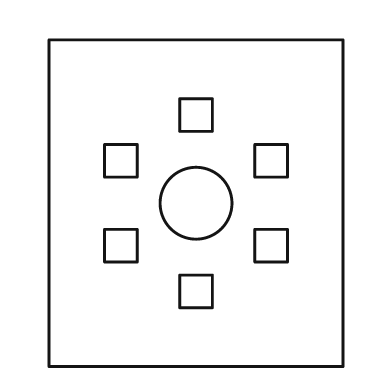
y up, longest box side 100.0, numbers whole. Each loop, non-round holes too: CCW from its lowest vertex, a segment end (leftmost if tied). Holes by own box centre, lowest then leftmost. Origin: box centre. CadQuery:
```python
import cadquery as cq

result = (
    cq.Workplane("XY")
    .moveTo(-45.0, -50.0)
    .lineTo(45.0, -50.0)
    .lineTo(45.0, 50.0)
    .lineTo(-45.0, 50.0)
    .close()
    .moveTo(-5.0, -32.0)
    .lineTo(5.0, -32.0)
    .lineTo(5.0, -22.0)
    .lineTo(-5.0, -22.0)
    .close()
    .moveTo(-28.0, -18.0)
    .lineTo(-18.0, -18.0)
    .lineTo(-18.0, -8.0)
    .lineTo(-28.0, -8.0)
    .close()
    .moveTo(18.0, -18.0)
    .lineTo(28.0, -18.0)
    .lineTo(28.0, -8.0)
    .lineTo(18.0, -8.0)
    .close()
    .moveTo(0.0, 0.0)
    .circle(11.0)
    .moveTo(-28.0, 8.0)
    .lineTo(-18.0, 8.0)
    .lineTo(-18.0, 18.0)
    .lineTo(-28.0, 18.0)
    .close()
    .moveTo(18.0, 8.0)
    .lineTo(28.0, 8.0)
    .lineTo(28.0, 18.0)
    .lineTo(18.0, 18.0)
    .close()
    .moveTo(-5.0, 22.0)
    .lineTo(5.0, 22.0)
    .lineTo(5.0, 32.0)
    .lineTo(-5.0, 32.0)
    .close()
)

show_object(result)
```